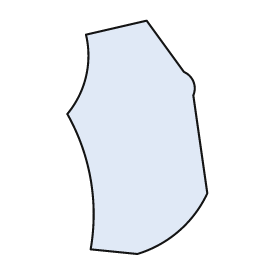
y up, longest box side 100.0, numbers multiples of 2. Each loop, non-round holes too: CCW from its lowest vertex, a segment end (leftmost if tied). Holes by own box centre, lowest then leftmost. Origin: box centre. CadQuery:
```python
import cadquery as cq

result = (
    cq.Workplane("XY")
    .moveTo(0.0, -50.0)
    .threePointArc((18.0, -40.0), (30.0, -24.0))
    .lineTo(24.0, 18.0)
    .threePointArc((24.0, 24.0), (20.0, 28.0))
    .lineTo(4.0, 50.0)
    .lineTo(-22.0, 44.0)
    .threePointArc((-22.0, 26.0), (-30.0, 10.0))
    .threePointArc((-20.0, -18.0), (-20.0, -48.0))
    .close()
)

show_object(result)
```